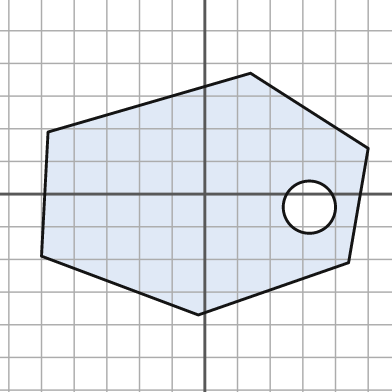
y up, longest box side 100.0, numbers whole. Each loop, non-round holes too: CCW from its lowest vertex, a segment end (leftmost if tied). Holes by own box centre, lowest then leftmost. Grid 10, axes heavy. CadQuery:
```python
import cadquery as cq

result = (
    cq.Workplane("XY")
    .moveTo(-2.0, -37.0)
    .lineTo(44.0, -21.0)
    .lineTo(50.0, 14.0)
    .lineTo(14.0, 37.0)
    .lineTo(-48.0, 19.0)
    .lineTo(-50.0, -19.0)
    .close()
    .moveTo(32.0, -4.0)
    .circle(8.0)
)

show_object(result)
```